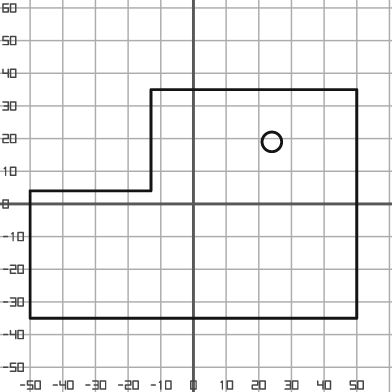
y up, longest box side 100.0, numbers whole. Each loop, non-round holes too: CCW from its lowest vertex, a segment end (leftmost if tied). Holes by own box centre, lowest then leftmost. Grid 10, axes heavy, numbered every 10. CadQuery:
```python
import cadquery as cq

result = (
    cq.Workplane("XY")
    .moveTo(-50.0, -35.0)
    .lineTo(50.0, -35.0)
    .lineTo(50.0, 35.0)
    .lineTo(-13.0, 35.0)
    .lineTo(-13.0, 4.0)
    .lineTo(-50.0, 4.0)
    .close()
    .moveTo(24.0, 19.0)
    .circle(3.0)
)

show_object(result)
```